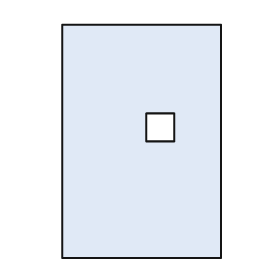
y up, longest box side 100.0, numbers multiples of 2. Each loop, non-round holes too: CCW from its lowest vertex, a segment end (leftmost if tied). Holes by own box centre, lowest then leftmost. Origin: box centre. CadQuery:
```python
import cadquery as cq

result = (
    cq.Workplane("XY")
    .moveTo(-34.0, -50.0)
    .lineTo(34.0, -50.0)
    .lineTo(34.0, 50.0)
    .lineTo(-34.0, 50.0)
    .close()
    .moveTo(2.0, 0.0)
    .lineTo(14.0, 0.0)
    .lineTo(14.0, 12.0)
    .lineTo(2.0, 12.0)
    .close()
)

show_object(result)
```